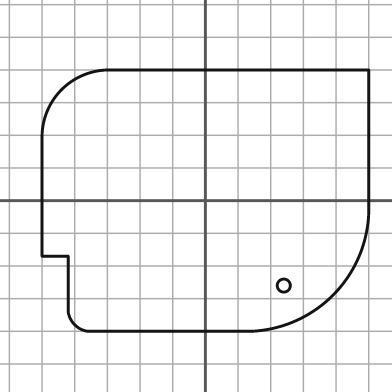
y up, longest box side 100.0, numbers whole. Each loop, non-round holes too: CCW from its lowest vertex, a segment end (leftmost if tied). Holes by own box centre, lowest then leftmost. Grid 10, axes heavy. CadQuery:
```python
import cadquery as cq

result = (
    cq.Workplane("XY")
    .moveTo(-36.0, -40.0)
    .lineTo(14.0, -40.0)
    .threePointArc((39.0, -29.0), (50.0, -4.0))
    .lineTo(50.0, 40.0)
    .lineTo(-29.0, 40.0)
    .threePointArc((-44.0, 34.0), (-50.0, 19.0))
    .lineTo(-50.0, -17.0)
    .lineTo(-42.0, -17.0)
    .lineTo(-42.0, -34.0)
    .threePointArc((-40.0, -38.0), (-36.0, -40.0))
    .close()
    .moveTo(24.0, -26.0)
    .circle(2.0)
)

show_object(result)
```